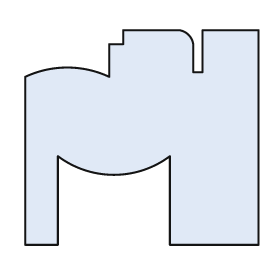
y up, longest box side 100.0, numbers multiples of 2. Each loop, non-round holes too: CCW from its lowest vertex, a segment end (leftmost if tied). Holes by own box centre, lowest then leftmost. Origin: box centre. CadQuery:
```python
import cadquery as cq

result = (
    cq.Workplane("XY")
    .moveTo(-50.0, -46.0)
    .lineTo(-36.0, -46.0)
    .lineTo(-36.0, -8.0)
    .threePointArc((-12.0, -16.0), (12.0, -8.0))
    .lineTo(12.0, -46.0)
    .lineTo(50.0, -46.0)
    .lineTo(50.0, 46.0)
    .lineTo(26.0, 46.0)
    .lineTo(26.0, 28.0)
    .lineTo(22.0, 28.0)
    .lineTo(22.0, 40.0)
    .threePointArc((20.0, 44.0), (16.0, 46.0))
    .lineTo(-8.0, 46.0)
    .lineTo(-8.0, 40.0)
    .lineTo(-14.0, 40.0)
    .lineTo(-14.0, 26.0)
    .threePointArc((-32.0, 30.0), (-50.0, 26.0))
    .close()
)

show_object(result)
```